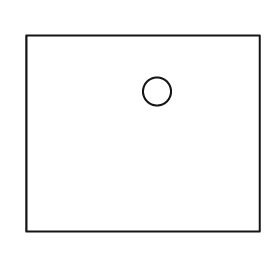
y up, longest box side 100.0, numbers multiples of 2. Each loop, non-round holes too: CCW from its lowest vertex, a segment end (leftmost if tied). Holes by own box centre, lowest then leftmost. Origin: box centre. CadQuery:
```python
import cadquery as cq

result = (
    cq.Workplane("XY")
    .moveTo(-50.0, -42.0)
    .lineTo(50.0, -42.0)
    .lineTo(50.0, 42.0)
    .lineTo(-50.0, 42.0)
    .close()
    .moveTo(6.0, 18.0)
    .circle(6.0)
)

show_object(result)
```